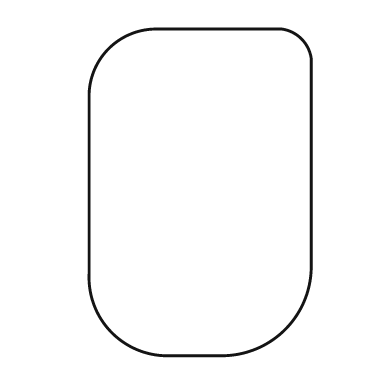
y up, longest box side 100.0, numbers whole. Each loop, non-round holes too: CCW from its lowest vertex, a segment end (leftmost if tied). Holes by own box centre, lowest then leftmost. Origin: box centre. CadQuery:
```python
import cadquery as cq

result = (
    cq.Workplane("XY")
    .moveTo(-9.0, -50.0)
    .lineTo(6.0, -50.0)
    .threePointArc((26.0, -42.0), (34.0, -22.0))
    .lineTo(34.0, 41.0)
    .threePointArc((31.0, 47.0), (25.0, 50.0))
    .lineTo(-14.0, 50.0)
    .threePointArc((-28.0, 44.0), (-34.0, 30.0))
    .lineTo(-34.0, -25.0)
    .threePointArc((-27.0, -43.0), (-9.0, -50.0))
    .close()
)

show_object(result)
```